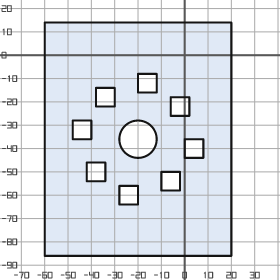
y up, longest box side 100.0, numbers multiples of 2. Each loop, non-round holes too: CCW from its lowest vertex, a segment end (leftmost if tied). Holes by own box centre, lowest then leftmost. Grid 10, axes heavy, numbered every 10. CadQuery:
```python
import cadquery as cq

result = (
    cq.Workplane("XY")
    .moveTo(-60.0, -86.0)
    .lineTo(20.0, -86.0)
    .lineTo(20.0, 14.0)
    .lineTo(-60.0, 14.0)
    .close()
    .moveTo(-28.0, -64.0)
    .lineTo(-20.0, -64.0)
    .lineTo(-20.0, -56.0)
    .lineTo(-28.0, -56.0)
    .close()
    .moveTo(-10.0, -58.0)
    .lineTo(-2.0, -58.0)
    .lineTo(-2.0, -50.0)
    .lineTo(-10.0, -50.0)
    .close()
    .moveTo(-42.0, -54.0)
    .lineTo(-34.0, -54.0)
    .lineTo(-34.0, -46.0)
    .lineTo(-42.0, -46.0)
    .close()
    .moveTo(0.0, -44.0)
    .lineTo(8.0, -44.0)
    .lineTo(8.0, -36.0)
    .lineTo(0.0, -36.0)
    .close()
    .moveTo(-20.0, -36.0)
    .circle(8.0)
    .moveTo(-48.0, -36.0)
    .lineTo(-40.0, -36.0)
    .lineTo(-40.0, -28.0)
    .lineTo(-48.0, -28.0)
    .close()
    .moveTo(-6.0, -26.0)
    .lineTo(2.0, -26.0)
    .lineTo(2.0, -18.0)
    .lineTo(-6.0, -18.0)
    .close()
    .moveTo(-38.0, -22.0)
    .lineTo(-30.0, -22.0)
    .lineTo(-30.0, -14.0)
    .lineTo(-38.0, -14.0)
    .close()
    .moveTo(-20.0, -16.0)
    .lineTo(-12.0, -16.0)
    .lineTo(-12.0, -8.0)
    .lineTo(-20.0, -8.0)
    .close()
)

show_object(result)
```